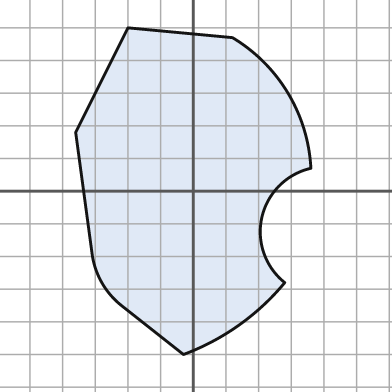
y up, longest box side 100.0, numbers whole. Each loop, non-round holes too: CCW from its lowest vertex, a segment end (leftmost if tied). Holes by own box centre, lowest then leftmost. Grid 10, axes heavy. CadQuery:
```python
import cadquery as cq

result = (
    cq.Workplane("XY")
    .moveTo(-3.0, -50.0)
    .threePointArc((14.0, -41.0), (28.0, -28.0))
    .threePointArc((21.0, -8.0), (36.0, 7.0))
    .threePointArc((29.0, 30.0), (12.0, 47.0))
    .lineTo(-20.0, 50.0)
    .lineTo(-36.0, 18.0)
    .lineTo(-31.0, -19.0)
    .threePointArc((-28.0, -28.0), (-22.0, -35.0))
    .close()
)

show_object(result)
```